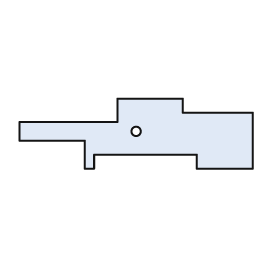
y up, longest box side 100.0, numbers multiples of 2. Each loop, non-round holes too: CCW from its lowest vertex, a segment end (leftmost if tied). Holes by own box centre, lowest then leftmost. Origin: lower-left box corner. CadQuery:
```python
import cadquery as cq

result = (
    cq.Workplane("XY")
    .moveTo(28.0, 0.0)
    .lineTo(32.0, 0.0)
    .lineTo(32.0, 6.0)
    .lineTo(76.0, 6.0)
    .lineTo(76.0, 0.0)
    .lineTo(100.0, 0.0)
    .lineTo(100.0, 24.0)
    .lineTo(70.0, 24.0)
    .lineTo(70.0, 30.0)
    .lineTo(42.0, 30.0)
    .lineTo(42.0, 20.0)
    .lineTo(0.0, 20.0)
    .lineTo(0.0, 12.0)
    .lineTo(28.0, 12.0)
    .close()
    .moveTo(50.0, 16.0)
    .circle(2.0)
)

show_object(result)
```